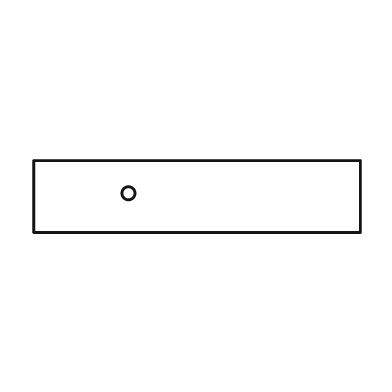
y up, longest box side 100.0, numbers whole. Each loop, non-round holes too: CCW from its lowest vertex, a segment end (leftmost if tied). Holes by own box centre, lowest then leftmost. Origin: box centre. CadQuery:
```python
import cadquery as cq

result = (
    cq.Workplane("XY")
    .moveTo(-50.0, -11.0)
    .lineTo(50.0, -11.0)
    .lineTo(50.0, 11.0)
    .lineTo(-50.0, 11.0)
    .close()
    .moveTo(-21.0, 1.0)
    .circle(2.0)
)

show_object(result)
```